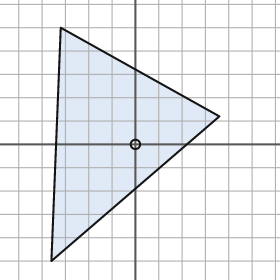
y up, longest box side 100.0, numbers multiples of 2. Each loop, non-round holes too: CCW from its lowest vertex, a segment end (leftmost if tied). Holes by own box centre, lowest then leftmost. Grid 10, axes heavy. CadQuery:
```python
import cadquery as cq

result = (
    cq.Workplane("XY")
    .moveTo(-36.0, -50.0)
    .lineTo(36.0, 12.0)
    .lineTo(-32.0, 50.0)
    .close()
    .moveTo(0.0, 0.0)
    .circle(2.0)
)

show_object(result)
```